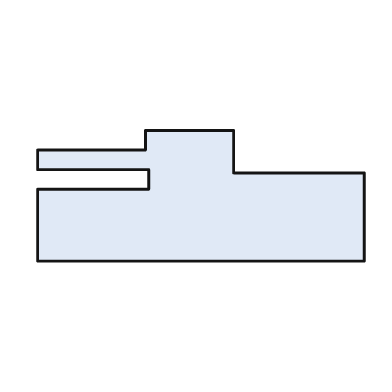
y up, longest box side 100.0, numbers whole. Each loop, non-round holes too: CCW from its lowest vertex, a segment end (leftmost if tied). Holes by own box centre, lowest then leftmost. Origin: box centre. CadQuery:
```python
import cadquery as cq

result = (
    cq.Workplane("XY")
    .moveTo(-50.0, -20.0)
    .lineTo(50.0, -20.0)
    .lineTo(50.0, 7.0)
    .lineTo(10.0, 7.0)
    .lineTo(10.0, 20.0)
    .lineTo(-17.0, 20.0)
    .lineTo(-17.0, 14.0)
    .lineTo(-50.0, 14.0)
    .lineTo(-50.0, 8.0)
    .lineTo(-16.0, 8.0)
    .lineTo(-16.0, 2.0)
    .lineTo(-50.0, 2.0)
    .close()
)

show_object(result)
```